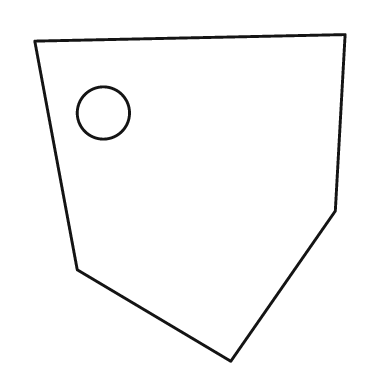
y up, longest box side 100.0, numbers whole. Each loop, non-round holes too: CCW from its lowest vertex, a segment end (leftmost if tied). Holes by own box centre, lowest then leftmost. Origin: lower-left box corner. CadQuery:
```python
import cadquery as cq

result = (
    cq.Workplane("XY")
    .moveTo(60.0, 0.0)
    .lineTo(92.0, 46.0)
    .lineTo(95.0, 100.0)
    .lineTo(0.0, 98.0)
    .lineTo(13.0, 28.0)
    .close()
    .moveTo(21.0, 76.0)
    .circle(8.0)
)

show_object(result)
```